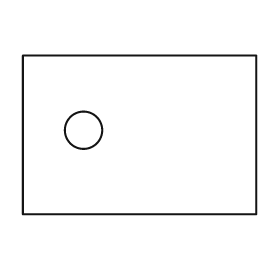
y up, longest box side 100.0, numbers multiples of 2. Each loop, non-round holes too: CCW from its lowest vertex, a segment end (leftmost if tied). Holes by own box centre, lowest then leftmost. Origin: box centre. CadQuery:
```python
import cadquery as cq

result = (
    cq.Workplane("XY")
    .moveTo(-50.0, -34.0)
    .lineTo(50.0, -34.0)
    .lineTo(50.0, 34.0)
    .lineTo(-50.0, 34.0)
    .close()
    .moveTo(-24.0, 2.0)
    .circle(8.0)
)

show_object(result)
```